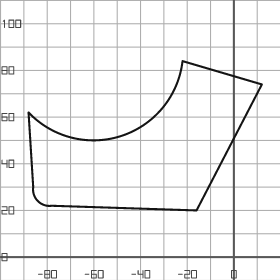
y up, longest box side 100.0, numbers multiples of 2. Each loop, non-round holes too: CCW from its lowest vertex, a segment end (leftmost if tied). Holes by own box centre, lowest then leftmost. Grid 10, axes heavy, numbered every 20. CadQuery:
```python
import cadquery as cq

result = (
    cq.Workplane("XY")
    .moveTo(-16.0, 20.0)
    .lineTo(12.0, 74.0)
    .lineTo(-22.0, 84.0)
    .threePointArc((-48.0, 52.0), (-88.0, 62.0))
    .lineTo(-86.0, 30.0)
    .threePointArc((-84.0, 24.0), (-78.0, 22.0))
    .close()
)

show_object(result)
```